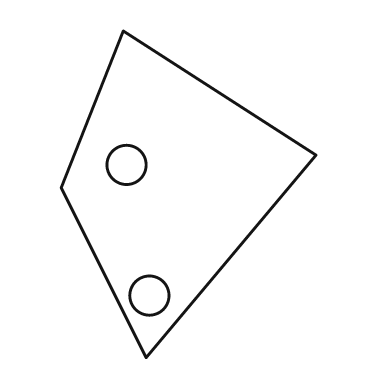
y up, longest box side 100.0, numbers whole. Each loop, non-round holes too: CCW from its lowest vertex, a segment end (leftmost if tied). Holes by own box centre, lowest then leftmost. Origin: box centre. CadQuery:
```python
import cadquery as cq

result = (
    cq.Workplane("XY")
    .moveTo(-13.0, -50.0)
    .lineTo(39.0, 12.0)
    .lineTo(-20.0, 50.0)
    .lineTo(-39.0, 2.0)
    .close()
    .moveTo(-12.0, -31.0)
    .circle(6.0)
    .moveTo(-19.0, 9.0)
    .circle(6.0)
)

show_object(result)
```